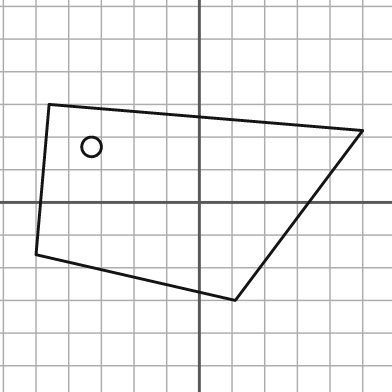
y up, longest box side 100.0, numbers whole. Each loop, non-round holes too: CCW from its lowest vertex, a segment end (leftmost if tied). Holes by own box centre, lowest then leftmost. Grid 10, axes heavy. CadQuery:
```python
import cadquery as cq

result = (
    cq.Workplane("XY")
    .moveTo(11.0, -30.0)
    .lineTo(50.0, 22.0)
    .lineTo(-46.0, 30.0)
    .lineTo(-50.0, -16.0)
    .close()
    .moveTo(-33.0, 17.0)
    .circle(3.0)
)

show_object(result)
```